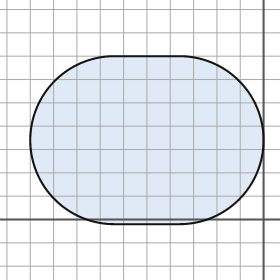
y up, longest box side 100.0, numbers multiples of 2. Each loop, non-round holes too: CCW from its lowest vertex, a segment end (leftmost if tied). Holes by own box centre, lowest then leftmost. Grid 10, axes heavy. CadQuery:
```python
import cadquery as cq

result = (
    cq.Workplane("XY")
    .moveTo(-64.0, -2.0)
    .lineTo(-36.0, -2.0)
    .threePointArc((0.0, 34.0), (-36.0, 70.0))
    .lineTo(-64.0, 70.0)
    .threePointArc((-100.0, 34.0), (-64.0, -2.0))
    .close()
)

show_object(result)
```